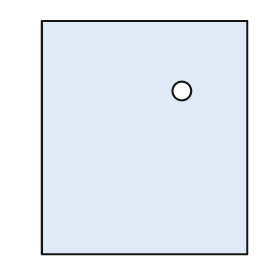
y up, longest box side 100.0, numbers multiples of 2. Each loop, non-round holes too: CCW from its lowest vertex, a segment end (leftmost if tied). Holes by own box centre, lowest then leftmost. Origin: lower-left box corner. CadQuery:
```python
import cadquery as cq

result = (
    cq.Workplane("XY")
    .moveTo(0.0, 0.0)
    .lineTo(88.0, 0.0)
    .lineTo(88.0, 100.0)
    .lineTo(0.0, 100.0)
    .close()
    .moveTo(60.0, 70.0)
    .circle(4.0)
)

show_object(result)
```